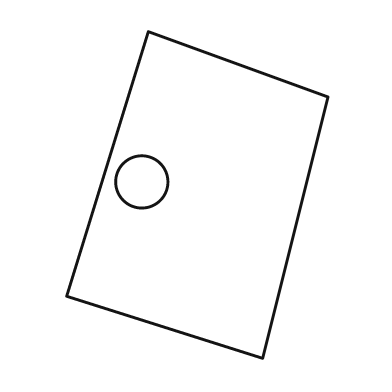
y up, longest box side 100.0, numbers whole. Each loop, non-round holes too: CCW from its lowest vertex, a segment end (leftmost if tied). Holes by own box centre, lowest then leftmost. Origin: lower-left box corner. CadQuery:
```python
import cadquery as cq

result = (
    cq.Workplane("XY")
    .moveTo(60.0, 0.0)
    .lineTo(80.0, 80.0)
    .lineTo(25.0, 100.0)
    .lineTo(0.0, 19.0)
    .close()
    .moveTo(23.0, 54.0)
    .circle(8.0)
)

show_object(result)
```